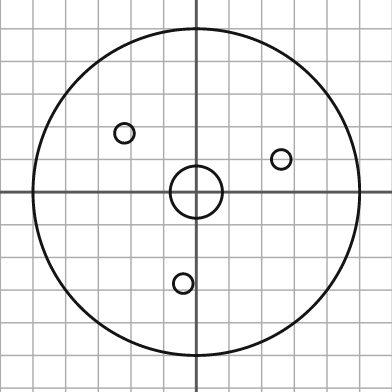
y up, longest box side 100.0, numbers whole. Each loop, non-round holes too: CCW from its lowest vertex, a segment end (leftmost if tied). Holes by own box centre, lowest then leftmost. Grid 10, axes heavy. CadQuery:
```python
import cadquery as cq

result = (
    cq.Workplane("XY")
    .moveTo(0.0, 0.0)
    .circle(50.0)
    .moveTo(-4.0, -28.0)
    .circle(3.0)
    .moveTo(0.0, 0.0)
    .circle(8.0)
    .moveTo(26.0, 10.0)
    .circle(3.0)
    .moveTo(-22.0, 18.0)
    .circle(3.0)
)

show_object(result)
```